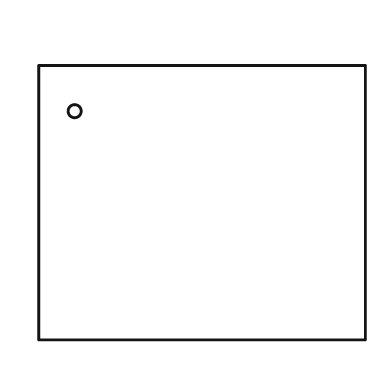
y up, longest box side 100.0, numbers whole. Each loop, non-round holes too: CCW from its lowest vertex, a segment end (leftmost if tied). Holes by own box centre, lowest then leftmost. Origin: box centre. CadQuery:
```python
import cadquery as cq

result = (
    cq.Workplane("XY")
    .moveTo(-50.0, -42.0)
    .lineTo(50.0, -42.0)
    .lineTo(50.0, 42.0)
    .lineTo(-50.0, 42.0)
    .close()
    .moveTo(-39.0, 28.0)
    .circle(2.0)
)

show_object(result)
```